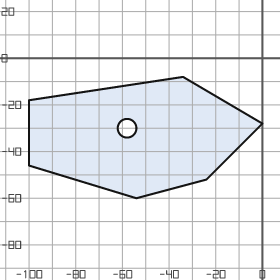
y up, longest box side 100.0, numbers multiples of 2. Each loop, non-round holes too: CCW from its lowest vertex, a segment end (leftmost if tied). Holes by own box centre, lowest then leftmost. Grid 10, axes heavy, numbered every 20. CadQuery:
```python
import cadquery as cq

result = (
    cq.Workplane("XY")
    .moveTo(-54.0, -60.0)
    .lineTo(-24.0, -52.0)
    .lineTo(0.0, -28.0)
    .lineTo(-34.0, -8.0)
    .lineTo(-100.0, -18.0)
    .lineTo(-100.0, -46.0)
    .close()
    .moveTo(-58.0, -30.0)
    .circle(4.0)
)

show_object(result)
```